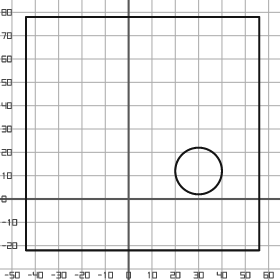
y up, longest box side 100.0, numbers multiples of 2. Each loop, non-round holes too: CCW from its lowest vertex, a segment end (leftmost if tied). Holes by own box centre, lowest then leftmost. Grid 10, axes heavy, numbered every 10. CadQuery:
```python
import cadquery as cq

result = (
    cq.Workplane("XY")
    .moveTo(-44.0, -22.0)
    .lineTo(56.0, -22.0)
    .lineTo(56.0, 78.0)
    .lineTo(-44.0, 78.0)
    .close()
    .moveTo(30.0, 12.0)
    .circle(10.0)
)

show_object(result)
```